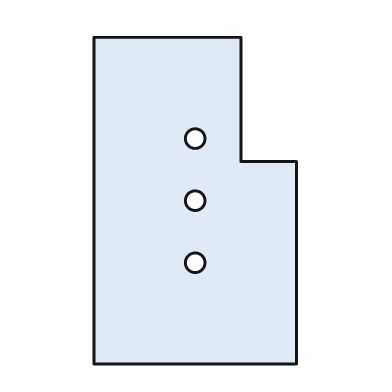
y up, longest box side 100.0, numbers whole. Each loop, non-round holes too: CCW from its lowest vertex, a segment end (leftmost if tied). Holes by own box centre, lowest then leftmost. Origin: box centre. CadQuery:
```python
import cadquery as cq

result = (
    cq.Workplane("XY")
    .moveTo(-31.0, -50.0)
    .lineTo(31.0, -50.0)
    .lineTo(31.0, 12.0)
    .lineTo(14.0, 12.0)
    .lineTo(14.0, 50.0)
    .lineTo(-31.0, 50.0)
    .close()
    .moveTo(0.0, -19.0)
    .circle(3.0)
    .moveTo(0.0, 0.0)
    .circle(3.0)
    .moveTo(0.0, 19.0)
    .circle(3.0)
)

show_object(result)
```